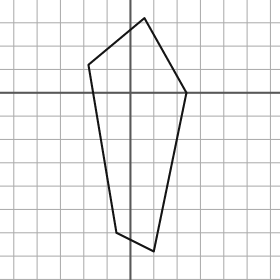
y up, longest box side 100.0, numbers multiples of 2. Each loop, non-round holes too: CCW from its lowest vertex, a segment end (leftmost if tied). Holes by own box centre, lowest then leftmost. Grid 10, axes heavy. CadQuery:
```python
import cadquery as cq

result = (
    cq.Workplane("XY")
    .moveTo(10.0, -68.0)
    .lineTo(24.0, 0.0)
    .lineTo(6.0, 32.0)
    .lineTo(-18.0, 12.0)
    .lineTo(-6.0, -60.0)
    .close()
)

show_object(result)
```